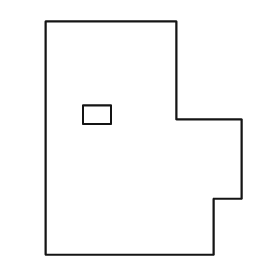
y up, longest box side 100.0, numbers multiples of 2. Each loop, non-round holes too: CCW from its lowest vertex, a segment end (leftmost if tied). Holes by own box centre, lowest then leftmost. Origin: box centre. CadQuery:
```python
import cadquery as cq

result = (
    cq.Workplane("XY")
    .moveTo(-42.0, -50.0)
    .lineTo(30.0, -50.0)
    .lineTo(30.0, -26.0)
    .lineTo(42.0, -26.0)
    .lineTo(42.0, 8.0)
    .lineTo(14.0, 8.0)
    .lineTo(14.0, 50.0)
    .lineTo(-42.0, 50.0)
    .close()
    .moveTo(-26.0, 6.0)
    .lineTo(-14.0, 6.0)
    .lineTo(-14.0, 14.0)
    .lineTo(-26.0, 14.0)
    .close()
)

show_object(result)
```